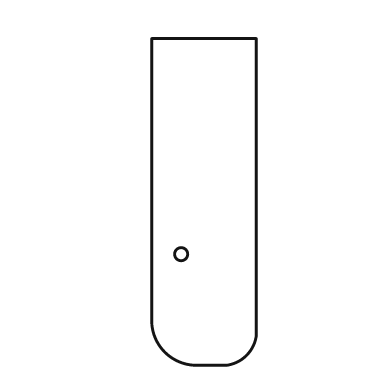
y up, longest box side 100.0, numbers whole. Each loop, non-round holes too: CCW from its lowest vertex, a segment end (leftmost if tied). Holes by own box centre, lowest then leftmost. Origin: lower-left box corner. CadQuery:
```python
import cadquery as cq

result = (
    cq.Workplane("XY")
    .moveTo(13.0, 0.0)
    .lineTo(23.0, 0.0)
    .threePointArc((29.0, 3.0), (32.0, 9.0))
    .lineTo(32.0, 100.0)
    .lineTo(0.0, 100.0)
    .lineTo(0.0, 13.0)
    .threePointArc((4.0, 4.0), (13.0, 0.0))
    .close()
    .moveTo(9.0, 34.0)
    .circle(2.0)
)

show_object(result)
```